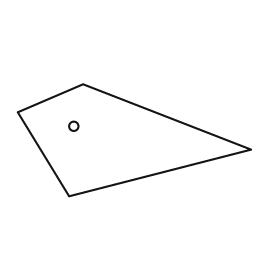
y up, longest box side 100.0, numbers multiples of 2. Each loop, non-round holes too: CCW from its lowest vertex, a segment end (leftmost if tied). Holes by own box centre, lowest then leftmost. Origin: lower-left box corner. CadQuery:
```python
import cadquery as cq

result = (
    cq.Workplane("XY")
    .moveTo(22.0, 0.0)
    .lineTo(100.0, 20.0)
    .lineTo(28.0, 48.0)
    .lineTo(0.0, 36.0)
    .close()
    .moveTo(24.0, 30.0)
    .circle(2.0)
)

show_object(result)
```